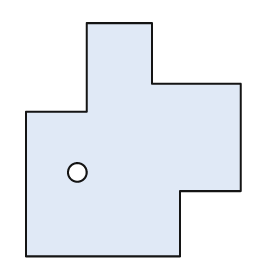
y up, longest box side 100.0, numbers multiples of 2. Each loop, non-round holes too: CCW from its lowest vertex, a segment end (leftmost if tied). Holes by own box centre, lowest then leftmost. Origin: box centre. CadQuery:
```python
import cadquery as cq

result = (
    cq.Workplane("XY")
    .moveTo(-46.0, -50.0)
    .lineTo(20.0, -50.0)
    .lineTo(20.0, -22.0)
    .lineTo(46.0, -22.0)
    .lineTo(46.0, 24.0)
    .lineTo(8.0, 24.0)
    .lineTo(8.0, 50.0)
    .lineTo(-20.0, 50.0)
    .lineTo(-20.0, 12.0)
    .lineTo(-46.0, 12.0)
    .close()
    .moveTo(-24.0, -14.0)
    .circle(4.0)
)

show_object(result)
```